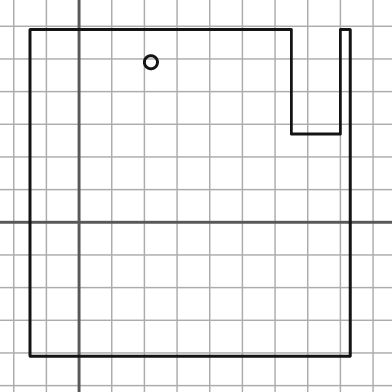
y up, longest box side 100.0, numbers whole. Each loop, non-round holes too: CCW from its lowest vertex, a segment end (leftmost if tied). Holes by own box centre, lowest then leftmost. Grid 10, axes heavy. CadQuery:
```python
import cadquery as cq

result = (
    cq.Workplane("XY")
    .moveTo(-15.0, -41.0)
    .lineTo(83.0, -41.0)
    .lineTo(83.0, 59.0)
    .lineTo(80.0, 59.0)
    .lineTo(80.0, 27.0)
    .lineTo(65.0, 27.0)
    .lineTo(65.0, 59.0)
    .lineTo(-15.0, 59.0)
    .close()
    .moveTo(22.0, 49.0)
    .circle(2.0)
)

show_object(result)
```